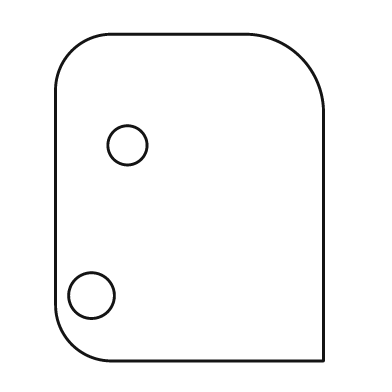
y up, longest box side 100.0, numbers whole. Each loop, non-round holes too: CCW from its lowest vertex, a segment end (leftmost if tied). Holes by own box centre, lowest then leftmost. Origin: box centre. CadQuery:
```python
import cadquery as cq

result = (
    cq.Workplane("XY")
    .moveTo(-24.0, -50.0)
    .lineTo(41.0, -50.0)
    .lineTo(41.0, 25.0)
    .threePointArc((34.0, 43.0), (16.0, 50.0))
    .lineTo(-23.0, 50.0)
    .threePointArc((-36.0, 45.0), (-41.0, 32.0))
    .lineTo(-41.0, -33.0)
    .threePointArc((-36.0, -45.0), (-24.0, -50.0))
    .close()
    .moveTo(-30.0, -30.0)
    .circle(7.0)
    .moveTo(-19.0, 16.0)
    .circle(6.0)
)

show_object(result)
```